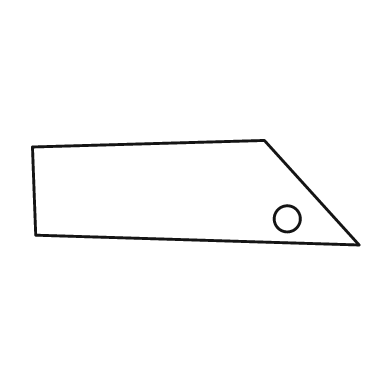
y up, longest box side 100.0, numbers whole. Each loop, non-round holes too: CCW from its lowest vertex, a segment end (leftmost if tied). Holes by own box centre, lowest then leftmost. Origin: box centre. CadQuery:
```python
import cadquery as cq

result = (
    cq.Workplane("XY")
    .moveTo(50.0, -16.0)
    .lineTo(21.0, 16.0)
    .lineTo(-50.0, 14.0)
    .lineTo(-49.0, -13.0)
    .close()
    .moveTo(28.0, -8.0)
    .circle(4.0)
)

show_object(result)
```